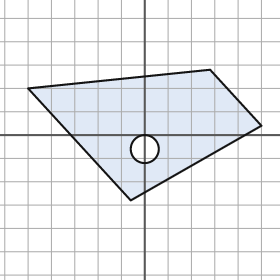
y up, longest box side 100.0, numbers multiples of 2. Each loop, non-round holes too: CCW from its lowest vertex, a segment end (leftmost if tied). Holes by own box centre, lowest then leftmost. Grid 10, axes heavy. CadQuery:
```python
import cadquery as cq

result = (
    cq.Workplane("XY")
    .moveTo(-6.0, -28.0)
    .lineTo(50.0, 4.0)
    .lineTo(28.0, 28.0)
    .lineTo(-50.0, 20.0)
    .close()
    .moveTo(0.0, -6.0)
    .circle(6.0)
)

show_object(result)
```